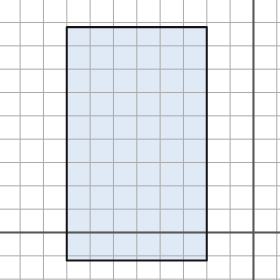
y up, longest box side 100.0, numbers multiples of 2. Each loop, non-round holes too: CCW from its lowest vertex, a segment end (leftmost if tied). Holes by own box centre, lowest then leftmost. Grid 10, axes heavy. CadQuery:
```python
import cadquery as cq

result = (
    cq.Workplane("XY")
    .moveTo(-80.0, -12.0)
    .lineTo(-20.0, -12.0)
    .lineTo(-20.0, 88.0)
    .lineTo(-80.0, 88.0)
    .close()
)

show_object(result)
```